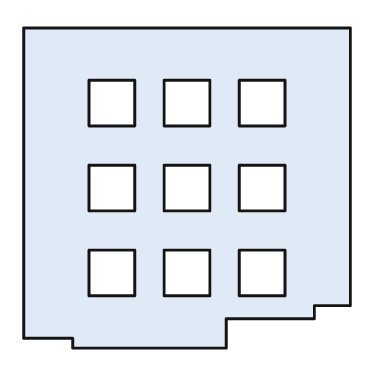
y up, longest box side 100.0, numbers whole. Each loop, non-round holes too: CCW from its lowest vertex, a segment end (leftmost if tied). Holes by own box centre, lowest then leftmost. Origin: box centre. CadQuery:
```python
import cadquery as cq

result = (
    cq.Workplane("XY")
    .moveTo(-35.0, -49.0)
    .lineTo(12.0, -49.0)
    .lineTo(12.0, -40.0)
    .lineTo(39.0, -40.0)
    .lineTo(39.0, -36.0)
    .lineTo(50.0, -36.0)
    .lineTo(50.0, 49.0)
    .lineTo(-50.0, 49.0)
    .lineTo(-50.0, -46.0)
    .lineTo(-35.0, -46.0)
    .close()
    .moveTo(-30.0, -33.0)
    .lineTo(-16.0, -33.0)
    .lineTo(-16.0, -19.0)
    .lineTo(-30.0, -19.0)
    .close()
    .moveTo(-7.0, -33.0)
    .lineTo(7.0, -33.0)
    .lineTo(7.0, -19.0)
    .lineTo(-7.0, -19.0)
    .close()
    .moveTo(16.0, -33.0)
    .lineTo(30.0, -33.0)
    .lineTo(30.0, -19.0)
    .lineTo(16.0, -19.0)
    .close()
    .moveTo(-30.0, -7.0)
    .lineTo(-16.0, -7.0)
    .lineTo(-16.0, 7.0)
    .lineTo(-30.0, 7.0)
    .close()
    .moveTo(-7.0, -7.0)
    .lineTo(7.0, -7.0)
    .lineTo(7.0, 7.0)
    .lineTo(-7.0, 7.0)
    .close()
    .moveTo(16.0, -7.0)
    .lineTo(30.0, -7.0)
    .lineTo(30.0, 7.0)
    .lineTo(16.0, 7.0)
    .close()
    .moveTo(-30.0, 19.0)
    .lineTo(-16.0, 19.0)
    .lineTo(-16.0, 33.0)
    .lineTo(-30.0, 33.0)
    .close()
    .moveTo(-7.0, 19.0)
    .lineTo(7.0, 19.0)
    .lineTo(7.0, 33.0)
    .lineTo(-7.0, 33.0)
    .close()
    .moveTo(16.0, 19.0)
    .lineTo(30.0, 19.0)
    .lineTo(30.0, 33.0)
    .lineTo(16.0, 33.0)
    .close()
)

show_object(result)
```